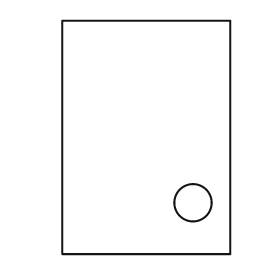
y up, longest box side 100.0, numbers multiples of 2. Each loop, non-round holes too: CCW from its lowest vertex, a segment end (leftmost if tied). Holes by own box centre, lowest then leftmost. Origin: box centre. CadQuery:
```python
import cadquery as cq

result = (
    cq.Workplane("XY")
    .moveTo(-36.0, -50.0)
    .lineTo(36.0, -50.0)
    .lineTo(36.0, 50.0)
    .lineTo(-36.0, 50.0)
    .close()
    .moveTo(20.0, -28.0)
    .circle(8.0)
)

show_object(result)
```